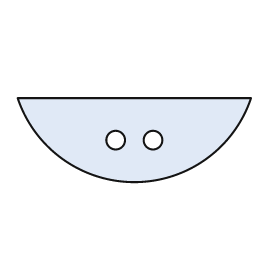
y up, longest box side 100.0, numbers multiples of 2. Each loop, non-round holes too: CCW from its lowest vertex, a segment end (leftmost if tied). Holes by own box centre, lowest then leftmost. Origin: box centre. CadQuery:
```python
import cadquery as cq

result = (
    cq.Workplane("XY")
    .moveTo(-50.0, 18.0)
    .threePointArc((0.0, -18.0), (50.0, 18.0))
    .close()
    .moveTo(-8.0, 0.0)
    .circle(4.0)
    .moveTo(8.0, 0.0)
    .circle(4.0)
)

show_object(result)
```